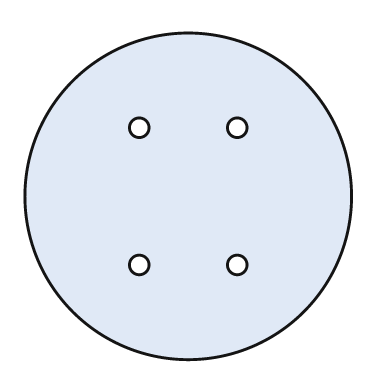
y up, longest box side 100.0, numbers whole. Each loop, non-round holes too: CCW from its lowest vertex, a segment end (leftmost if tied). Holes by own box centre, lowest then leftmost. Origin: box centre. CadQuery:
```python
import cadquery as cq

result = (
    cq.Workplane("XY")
    .moveTo(0.0, 0.0)
    .circle(50.0)
    .moveTo(-15.0, -21.0)
    .circle(3.0)
    .moveTo(15.0, -21.0)
    .circle(3.0)
    .moveTo(-15.0, 21.0)
    .circle(3.0)
    .moveTo(15.0, 21.0)
    .circle(3.0)
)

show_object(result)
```